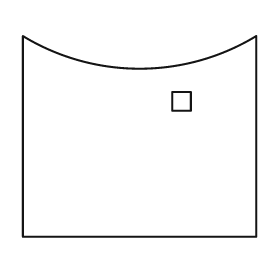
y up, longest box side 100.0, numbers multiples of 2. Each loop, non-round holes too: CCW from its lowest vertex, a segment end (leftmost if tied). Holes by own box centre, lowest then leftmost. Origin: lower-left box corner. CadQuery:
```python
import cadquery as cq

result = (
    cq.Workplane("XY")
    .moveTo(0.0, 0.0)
    .lineTo(100.0, 0.0)
    .lineTo(100.0, 86.0)
    .threePointArc((50.0, 72.0), (0.0, 86.0))
    .close()
    .moveTo(64.0, 54.0)
    .lineTo(72.0, 54.0)
    .lineTo(72.0, 62.0)
    .lineTo(64.0, 62.0)
    .close()
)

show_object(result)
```